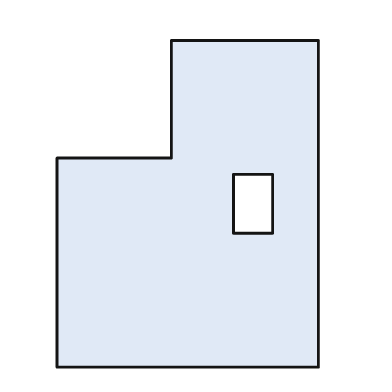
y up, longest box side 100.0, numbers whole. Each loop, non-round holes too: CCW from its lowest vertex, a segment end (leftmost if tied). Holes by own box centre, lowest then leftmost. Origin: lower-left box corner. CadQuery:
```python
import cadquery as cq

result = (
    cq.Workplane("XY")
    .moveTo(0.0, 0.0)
    .lineTo(80.0, 0.0)
    .lineTo(80.0, 100.0)
    .lineTo(35.0, 100.0)
    .lineTo(35.0, 64.0)
    .lineTo(0.0, 64.0)
    .close()
    .moveTo(54.0, 41.0)
    .lineTo(66.0, 41.0)
    .lineTo(66.0, 59.0)
    .lineTo(54.0, 59.0)
    .close()
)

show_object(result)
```